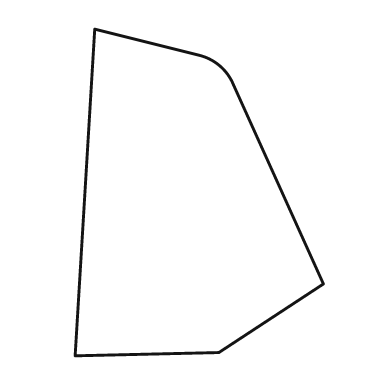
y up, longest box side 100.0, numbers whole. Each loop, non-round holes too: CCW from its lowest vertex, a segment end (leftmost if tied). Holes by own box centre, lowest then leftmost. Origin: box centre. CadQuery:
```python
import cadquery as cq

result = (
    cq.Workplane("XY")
    .moveTo(-38.0, -50.0)
    .lineTo(6.0, -49.0)
    .lineTo(38.0, -28.0)
    .lineTo(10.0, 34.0)
    .threePointArc((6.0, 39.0), (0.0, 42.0))
    .lineTo(-32.0, 50.0)
    .close()
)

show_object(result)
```